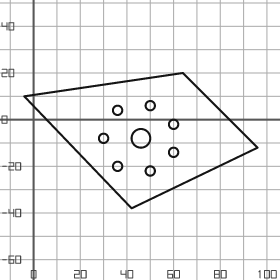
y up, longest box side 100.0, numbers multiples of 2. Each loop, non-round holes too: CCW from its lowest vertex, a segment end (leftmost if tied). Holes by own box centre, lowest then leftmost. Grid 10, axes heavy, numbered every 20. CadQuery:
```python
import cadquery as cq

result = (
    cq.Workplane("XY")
    .moveTo(42.0, -38.0)
    .lineTo(96.0, -12.0)
    .lineTo(64.0, 20.0)
    .lineTo(-4.0, 10.0)
    .close()
    .moveTo(50.0, -22.0)
    .circle(2.0)
    .moveTo(36.0, -20.0)
    .circle(2.0)
    .moveTo(60.0, -14.0)
    .circle(2.0)
    .moveTo(30.0, -8.0)
    .circle(2.0)
    .moveTo(46.0, -8.0)
    .circle(4.0)
    .moveTo(60.0, -2.0)
    .circle(2.0)
    .moveTo(36.0, 4.0)
    .circle(2.0)
    .moveTo(50.0, 6.0)
    .circle(2.0)
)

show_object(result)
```